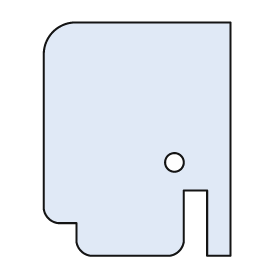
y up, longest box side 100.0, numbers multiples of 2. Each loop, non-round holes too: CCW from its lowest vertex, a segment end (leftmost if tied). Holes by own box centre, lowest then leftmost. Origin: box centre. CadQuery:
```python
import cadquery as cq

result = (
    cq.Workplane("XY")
    .moveTo(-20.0, -50.0)
    .lineTo(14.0, -50.0)
    .threePointArc((18.0, -48.0), (20.0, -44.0))
    .lineTo(20.0, -22.0)
    .lineTo(30.0, -22.0)
    .lineTo(30.0, -50.0)
    .lineTo(40.0, -50.0)
    .lineTo(40.0, 50.0)
    .lineTo(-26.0, 50.0)
    .threePointArc((-36.0, 46.0), (-40.0, 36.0))
    .lineTo(-40.0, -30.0)
    .threePointArc((-38.0, -34.0), (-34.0, -36.0))
    .lineTo(-26.0, -36.0)
    .lineTo(-26.0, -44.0)
    .threePointArc((-24.0, -48.0), (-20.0, -50.0))
    .close()
    .moveTo(16.0, -10.0)
    .circle(4.0)
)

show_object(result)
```